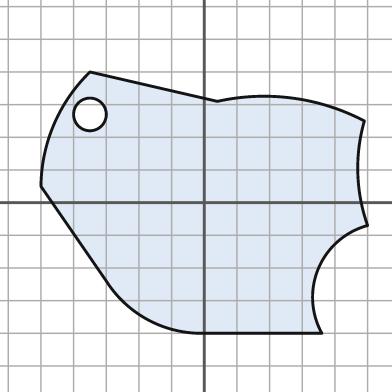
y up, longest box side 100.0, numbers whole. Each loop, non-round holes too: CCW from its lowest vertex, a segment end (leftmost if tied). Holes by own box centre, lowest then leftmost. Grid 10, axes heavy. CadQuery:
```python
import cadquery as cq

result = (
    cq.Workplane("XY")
    .moveTo(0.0, -40.0)
    .lineTo(36.0, -40.0)
    .threePointArc((35.0, -20.0), (50.0, -7.0))
    .threePointArc((47.0, 9.0), (49.0, 25.0))
    .threePointArc((27.0, 32.0), (4.0, 31.0))
    .lineTo(-35.0, 40.0)
    .threePointArc((-46.0, 24.0), (-50.0, 5.0))
    .lineTo(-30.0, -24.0)
    .threePointArc((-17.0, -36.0), (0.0, -40.0))
    .close()
    .moveTo(-35.0, 27.0)
    .circle(5.0)
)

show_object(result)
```